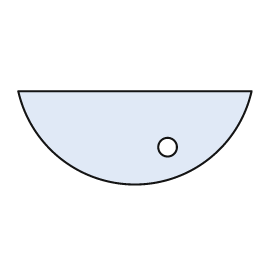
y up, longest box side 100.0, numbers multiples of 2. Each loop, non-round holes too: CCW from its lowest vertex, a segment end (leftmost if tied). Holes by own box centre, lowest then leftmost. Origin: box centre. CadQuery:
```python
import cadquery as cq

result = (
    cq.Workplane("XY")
    .moveTo(-50.0, 20.0)
    .threePointArc((0.0, -20.0), (50.0, 20.0))
    .close()
    .moveTo(14.0, -4.0)
    .circle(4.0)
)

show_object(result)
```